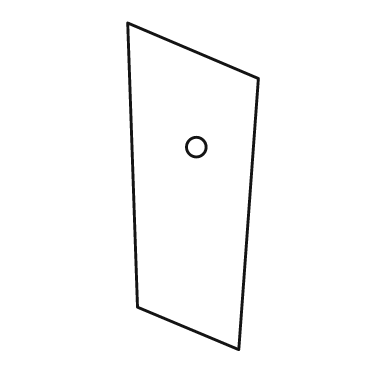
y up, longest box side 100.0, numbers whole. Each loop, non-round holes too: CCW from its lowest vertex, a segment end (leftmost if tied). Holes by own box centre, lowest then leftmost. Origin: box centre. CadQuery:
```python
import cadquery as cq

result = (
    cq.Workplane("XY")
    .moveTo(14.0, -50.0)
    .lineTo(20.0, 33.0)
    .lineTo(-20.0, 50.0)
    .lineTo(-17.0, -37.0)
    .close()
    .moveTo(1.0, 12.0)
    .circle(3.0)
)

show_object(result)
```